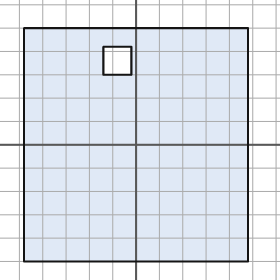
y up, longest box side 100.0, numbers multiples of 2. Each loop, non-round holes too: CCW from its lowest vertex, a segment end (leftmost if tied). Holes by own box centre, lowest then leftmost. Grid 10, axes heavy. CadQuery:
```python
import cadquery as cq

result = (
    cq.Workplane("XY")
    .moveTo(-48.0, -50.0)
    .lineTo(48.0, -50.0)
    .lineTo(48.0, 50.0)
    .lineTo(-48.0, 50.0)
    .close()
    .moveTo(-14.0, 30.0)
    .lineTo(-2.0, 30.0)
    .lineTo(-2.0, 42.0)
    .lineTo(-14.0, 42.0)
    .close()
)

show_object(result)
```